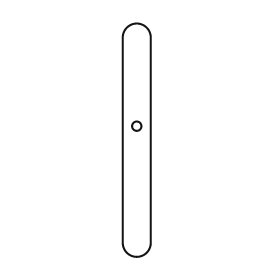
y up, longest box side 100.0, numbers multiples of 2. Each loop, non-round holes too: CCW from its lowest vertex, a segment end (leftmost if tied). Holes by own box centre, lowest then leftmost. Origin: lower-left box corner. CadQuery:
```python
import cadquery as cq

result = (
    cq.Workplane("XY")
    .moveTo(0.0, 6.0)
    .threePointArc((6.0, 0.0), (12.0, 6.0))
    .lineTo(12.0, 94.0)
    .threePointArc((6.0, 100.0), (0.0, 94.0))
    .close()
    .moveTo(6.0, 56.0)
    .circle(2.0)
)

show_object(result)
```